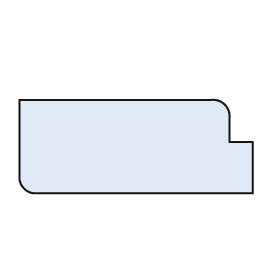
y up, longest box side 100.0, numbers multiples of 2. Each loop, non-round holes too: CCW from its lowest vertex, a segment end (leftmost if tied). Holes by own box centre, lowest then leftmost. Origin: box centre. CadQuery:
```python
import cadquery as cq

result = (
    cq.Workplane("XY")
    .moveTo(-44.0, -20.0)
    .lineTo(50.0, -20.0)
    .lineTo(50.0, 2.0)
    .lineTo(40.0, 2.0)
    .lineTo(40.0, 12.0)
    .threePointArc((38.0, 18.0), (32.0, 20.0))
    .lineTo(-50.0, 20.0)
    .lineTo(-50.0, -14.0)
    .threePointArc((-48.0, -18.0), (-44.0, -20.0))
    .close()
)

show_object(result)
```